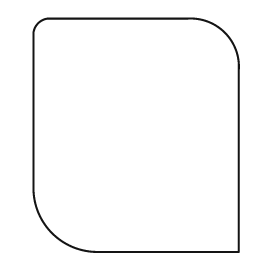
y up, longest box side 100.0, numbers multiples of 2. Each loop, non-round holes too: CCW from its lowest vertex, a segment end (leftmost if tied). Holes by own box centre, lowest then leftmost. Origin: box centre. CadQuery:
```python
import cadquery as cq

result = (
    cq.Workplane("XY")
    .moveTo(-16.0, -50.0)
    .lineTo(44.0, -50.0)
    .lineTo(44.0, 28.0)
    .threePointArc((38.0, 44.0), (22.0, 50.0))
    .lineTo(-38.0, 50.0)
    .threePointArc((-42.0, 48.0), (-44.0, 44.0))
    .lineTo(-44.0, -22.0)
    .threePointArc((-36.0, -42.0), (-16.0, -50.0))
    .close()
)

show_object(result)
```